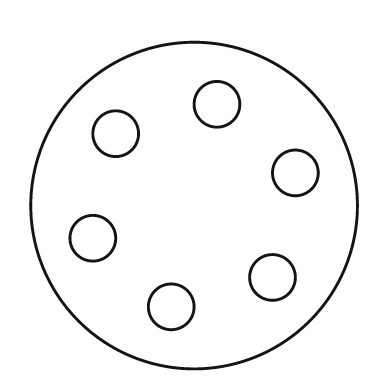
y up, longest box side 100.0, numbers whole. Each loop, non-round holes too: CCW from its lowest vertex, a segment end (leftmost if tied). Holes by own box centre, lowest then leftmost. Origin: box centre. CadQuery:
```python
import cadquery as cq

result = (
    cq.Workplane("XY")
    .moveTo(0.0, 0.0)
    .circle(50.0)
    .moveTo(-7.0, -31.0)
    .circle(7.0)
    .moveTo(24.0, -22.0)
    .circle(7.0)
    .moveTo(-31.0, -10.0)
    .circle(7.0)
    .moveTo(31.0, 10.0)
    .circle(7.0)
    .moveTo(-24.0, 22.0)
    .circle(7.0)
    .moveTo(7.0, 31.0)
    .circle(7.0)
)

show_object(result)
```